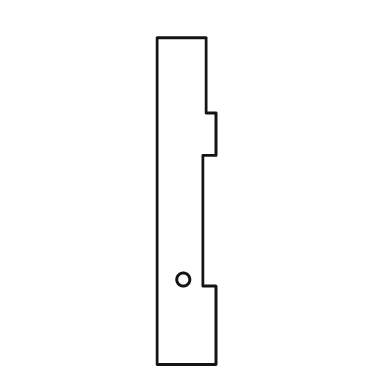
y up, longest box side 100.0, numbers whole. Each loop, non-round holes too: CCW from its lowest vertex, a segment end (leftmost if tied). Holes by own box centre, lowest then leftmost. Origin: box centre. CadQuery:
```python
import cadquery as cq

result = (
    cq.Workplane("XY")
    .moveTo(-9.0, -50.0)
    .lineTo(9.0, -50.0)
    .lineTo(9.0, -26.0)
    .lineTo(5.0, -26.0)
    .lineTo(5.0, 14.0)
    .lineTo(9.0, 14.0)
    .lineTo(9.0, 27.0)
    .lineTo(6.0, 27.0)
    .lineTo(6.0, 50.0)
    .lineTo(-9.0, 50.0)
    .close()
    .moveTo(-1.0, -24.0)
    .circle(2.0)
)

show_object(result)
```